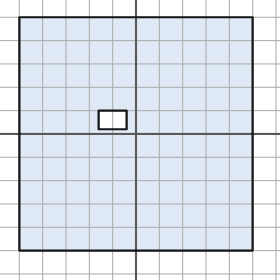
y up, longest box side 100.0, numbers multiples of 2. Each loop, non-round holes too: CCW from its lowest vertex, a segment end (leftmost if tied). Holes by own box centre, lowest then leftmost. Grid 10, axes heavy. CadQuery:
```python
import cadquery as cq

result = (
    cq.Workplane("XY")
    .moveTo(-50.0, -50.0)
    .lineTo(50.0, -50.0)
    .lineTo(50.0, 50.0)
    .lineTo(-50.0, 50.0)
    .close()
    .moveTo(-16.0, 2.0)
    .lineTo(-4.0, 2.0)
    .lineTo(-4.0, 10.0)
    .lineTo(-16.0, 10.0)
    .close()
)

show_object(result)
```